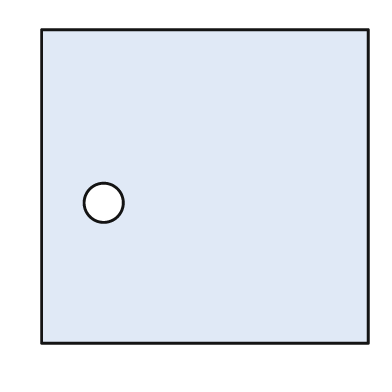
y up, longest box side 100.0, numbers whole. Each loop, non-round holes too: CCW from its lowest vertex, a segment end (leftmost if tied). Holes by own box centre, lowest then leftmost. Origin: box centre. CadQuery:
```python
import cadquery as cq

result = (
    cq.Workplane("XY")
    .moveTo(-50.0, -48.0)
    .lineTo(50.0, -48.0)
    .lineTo(50.0, 48.0)
    .lineTo(-50.0, 48.0)
    .close()
    .moveTo(-31.0, -5.0)
    .circle(6.0)
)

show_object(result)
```